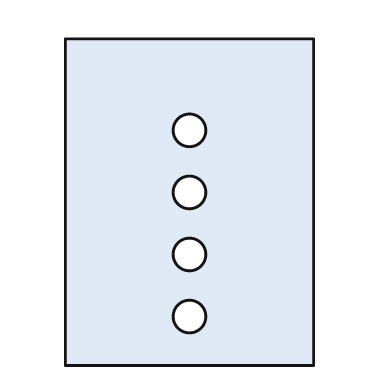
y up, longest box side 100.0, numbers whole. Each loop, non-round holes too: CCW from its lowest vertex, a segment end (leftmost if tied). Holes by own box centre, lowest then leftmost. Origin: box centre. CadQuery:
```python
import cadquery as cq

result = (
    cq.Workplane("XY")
    .moveTo(-38.0, -50.0)
    .lineTo(38.0, -50.0)
    .lineTo(38.0, 50.0)
    .lineTo(-38.0, 50.0)
    .close()
    .moveTo(0.0, -35.0)
    .circle(5.0)
    .moveTo(0.0, -16.0)
    .circle(5.0)
    .moveTo(0.0, 3.0)
    .circle(5.0)
    .moveTo(0.0, 22.0)
    .circle(5.0)
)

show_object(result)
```